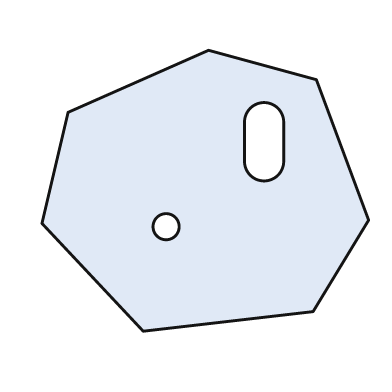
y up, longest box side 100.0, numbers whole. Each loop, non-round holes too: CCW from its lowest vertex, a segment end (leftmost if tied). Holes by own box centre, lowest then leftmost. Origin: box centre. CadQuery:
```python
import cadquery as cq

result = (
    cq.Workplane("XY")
    .moveTo(-19.0, -43.0)
    .lineTo(33.0, -37.0)
    .lineTo(50.0, -9.0)
    .lineTo(34.0, 34.0)
    .lineTo(1.0, 43.0)
    .lineTo(-42.0, 24.0)
    .lineTo(-50.0, -10.0)
    .close()
    .moveTo(-12.0, -11.0)
    .circle(4.0)
    .moveTo(12.0, 9.0)
    .threePointArc((18.0, 3.0), (24.0, 9.0))
    .lineTo(24.0, 21.0)
    .threePointArc((18.0, 27.0), (12.0, 21.0))
    .close()
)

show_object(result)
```